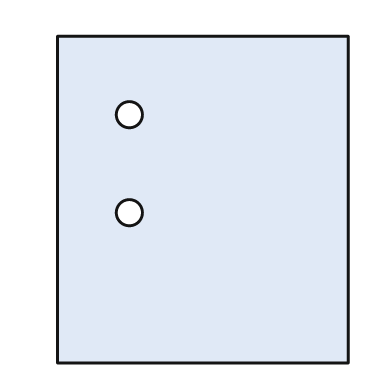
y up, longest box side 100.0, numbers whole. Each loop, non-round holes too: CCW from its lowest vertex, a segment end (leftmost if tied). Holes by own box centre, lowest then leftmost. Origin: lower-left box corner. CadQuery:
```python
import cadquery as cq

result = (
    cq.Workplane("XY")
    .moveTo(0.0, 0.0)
    .lineTo(89.0, 0.0)
    .lineTo(89.0, 100.0)
    .lineTo(0.0, 100.0)
    .close()
    .moveTo(22.0, 46.0)
    .circle(4.0)
    .moveTo(22.0, 76.0)
    .circle(4.0)
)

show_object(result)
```